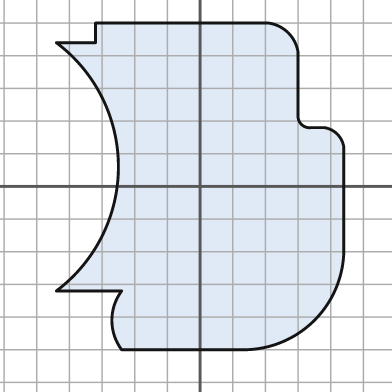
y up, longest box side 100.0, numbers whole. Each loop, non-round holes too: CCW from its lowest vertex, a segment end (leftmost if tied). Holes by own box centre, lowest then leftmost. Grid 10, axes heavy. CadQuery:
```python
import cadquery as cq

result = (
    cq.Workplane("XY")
    .moveTo(-24.0, -50.0)
    .lineTo(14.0, -50.0)
    .threePointArc((35.0, -41.0), (44.0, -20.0))
    .lineTo(44.0, 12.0)
    .threePointArc((42.0, 16.0), (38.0, 18.0))
    .lineTo(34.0, 18.0)
    .threePointArc((31.0, 19.0), (30.0, 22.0))
    .lineTo(30.0, 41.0)
    .threePointArc((27.0, 47.0), (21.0, 50.0))
    .lineTo(-32.0, 50.0)
    .lineTo(-32.0, 44.0)
    .lineTo(-44.0, 44.0)
    .threePointArc((-25.0, 6.0), (-44.0, -32.0))
    .lineTo(-24.0, -32.0)
    .threePointArc((-27.0, -41.0), (-24.0, -50.0))
    .close()
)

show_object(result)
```